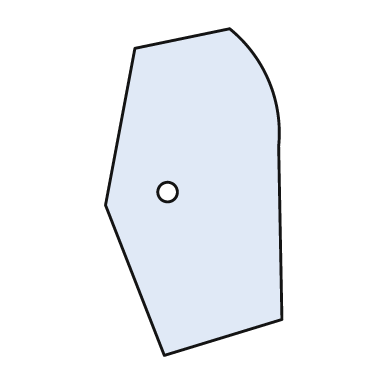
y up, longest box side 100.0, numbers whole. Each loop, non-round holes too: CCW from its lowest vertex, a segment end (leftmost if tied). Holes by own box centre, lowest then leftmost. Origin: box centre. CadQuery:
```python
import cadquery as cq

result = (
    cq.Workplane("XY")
    .moveTo(-9.0, -50.0)
    .lineTo(27.0, -39.0)
    .lineTo(26.0, 14.0)
    .threePointArc((23.0, 34.0), (11.0, 50.0))
    .lineTo(-18.0, 44.0)
    .lineTo(-27.0, -4.0)
    .close()
    .moveTo(-8.0, 0.0)
    .circle(3.0)
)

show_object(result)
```